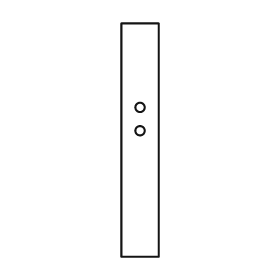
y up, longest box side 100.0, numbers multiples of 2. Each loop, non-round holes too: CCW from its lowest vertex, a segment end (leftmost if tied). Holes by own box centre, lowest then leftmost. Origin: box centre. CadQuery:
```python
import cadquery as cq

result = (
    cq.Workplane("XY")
    .moveTo(-8.0, -50.0)
    .lineTo(8.0, -50.0)
    .lineTo(8.0, 50.0)
    .lineTo(-8.0, 50.0)
    .close()
    .moveTo(0.0, 4.0)
    .circle(2.0)
    .moveTo(0.0, 14.0)
    .circle(2.0)
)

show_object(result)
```